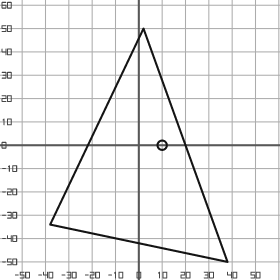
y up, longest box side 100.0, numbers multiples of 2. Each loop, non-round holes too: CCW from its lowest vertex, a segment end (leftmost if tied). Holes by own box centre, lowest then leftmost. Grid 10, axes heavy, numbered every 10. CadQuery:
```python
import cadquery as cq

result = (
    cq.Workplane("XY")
    .moveTo(38.0, -50.0)
    .lineTo(2.0, 50.0)
    .lineTo(-38.0, -34.0)
    .close()
    .moveTo(10.0, 0.0)
    .circle(2.0)
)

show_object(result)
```